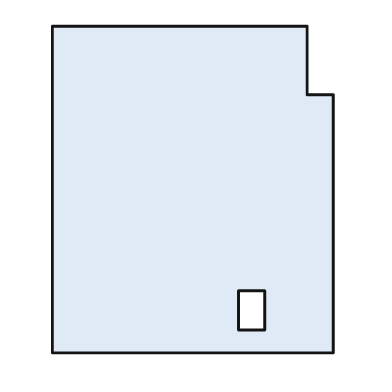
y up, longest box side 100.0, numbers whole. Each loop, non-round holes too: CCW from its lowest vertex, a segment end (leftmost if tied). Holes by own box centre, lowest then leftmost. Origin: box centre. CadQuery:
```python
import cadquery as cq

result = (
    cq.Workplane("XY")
    .moveTo(-43.0, -50.0)
    .lineTo(43.0, -50.0)
    .lineTo(43.0, 29.0)
    .lineTo(35.0, 29.0)
    .lineTo(35.0, 50.0)
    .lineTo(-43.0, 50.0)
    .close()
    .moveTo(14.0, -43.0)
    .lineTo(22.0, -43.0)
    .lineTo(22.0, -31.0)
    .lineTo(14.0, -31.0)
    .close()
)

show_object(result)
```